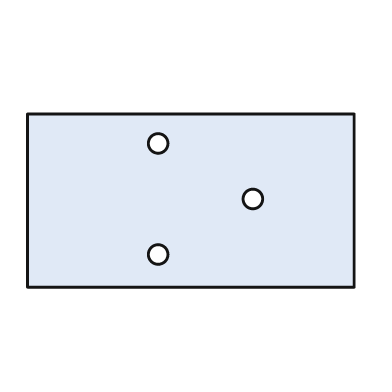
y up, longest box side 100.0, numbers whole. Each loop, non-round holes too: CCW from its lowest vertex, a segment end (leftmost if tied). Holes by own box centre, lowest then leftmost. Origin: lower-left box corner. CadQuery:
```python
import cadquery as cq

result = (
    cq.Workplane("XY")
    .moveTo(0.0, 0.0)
    .lineTo(100.0, 0.0)
    .lineTo(100.0, 53.0)
    .lineTo(0.0, 53.0)
    .close()
    .moveTo(40.0, 10.0)
    .circle(3.0)
    .moveTo(69.0, 27.0)
    .circle(3.0)
    .moveTo(40.0, 44.0)
    .circle(3.0)
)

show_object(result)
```